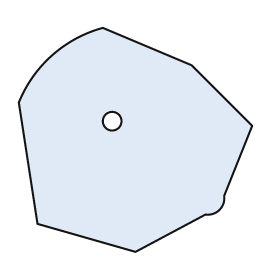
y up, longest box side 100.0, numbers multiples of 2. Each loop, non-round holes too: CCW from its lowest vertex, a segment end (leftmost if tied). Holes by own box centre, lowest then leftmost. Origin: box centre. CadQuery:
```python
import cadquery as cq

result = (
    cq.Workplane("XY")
    .moveTo(0.0, -48.0)
    .lineTo(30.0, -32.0)
    .threePointArc((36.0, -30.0), (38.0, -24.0))
    .lineTo(50.0, 6.0)
    .lineTo(24.0, 32.0)
    .lineTo(-14.0, 48.0)
    .threePointArc((-36.0, 36.0), (-50.0, 16.0))
    .lineTo(-42.0, -36.0)
    .close()
    .moveTo(-10.0, 8.0)
    .circle(4.0)
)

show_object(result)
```